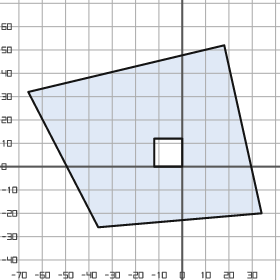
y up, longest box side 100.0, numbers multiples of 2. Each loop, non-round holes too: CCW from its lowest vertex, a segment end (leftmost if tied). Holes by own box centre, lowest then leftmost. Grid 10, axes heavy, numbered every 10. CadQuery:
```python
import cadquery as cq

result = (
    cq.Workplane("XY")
    .moveTo(-36.0, -26.0)
    .lineTo(34.0, -20.0)
    .lineTo(18.0, 52.0)
    .lineTo(-66.0, 32.0)
    .close()
    .moveTo(-12.0, 0.0)
    .lineTo(0.0, 0.0)
    .lineTo(0.0, 12.0)
    .lineTo(-12.0, 12.0)
    .close()
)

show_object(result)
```